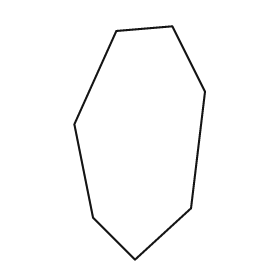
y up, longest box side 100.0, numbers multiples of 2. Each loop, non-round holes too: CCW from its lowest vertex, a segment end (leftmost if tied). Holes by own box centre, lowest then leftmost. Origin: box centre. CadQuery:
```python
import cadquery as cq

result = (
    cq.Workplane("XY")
    .moveTo(-2.0, -50.0)
    .lineTo(22.0, -28.0)
    .lineTo(28.0, 22.0)
    .lineTo(14.0, 50.0)
    .lineTo(-10.0, 48.0)
    .lineTo(-28.0, 8.0)
    .lineTo(-20.0, -32.0)
    .close()
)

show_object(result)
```